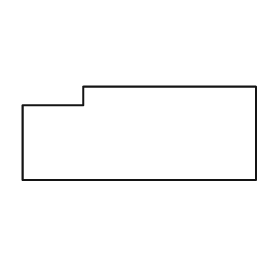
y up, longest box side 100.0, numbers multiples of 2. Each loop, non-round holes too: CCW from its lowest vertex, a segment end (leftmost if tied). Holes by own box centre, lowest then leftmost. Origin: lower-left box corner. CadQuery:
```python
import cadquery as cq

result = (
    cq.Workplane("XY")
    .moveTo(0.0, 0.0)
    .lineTo(100.0, 0.0)
    .lineTo(100.0, 40.0)
    .lineTo(26.0, 40.0)
    .lineTo(26.0, 32.0)
    .lineTo(0.0, 32.0)
    .close()
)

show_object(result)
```